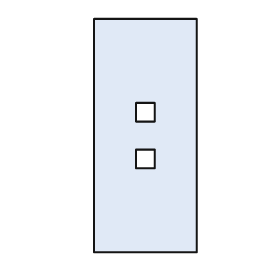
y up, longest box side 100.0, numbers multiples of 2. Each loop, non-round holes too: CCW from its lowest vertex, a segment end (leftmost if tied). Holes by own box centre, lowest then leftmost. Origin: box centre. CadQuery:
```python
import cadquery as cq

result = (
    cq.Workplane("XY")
    .moveTo(-22.0, -50.0)
    .lineTo(22.0, -50.0)
    .lineTo(22.0, 50.0)
    .lineTo(-22.0, 50.0)
    .close()
    .moveTo(-4.0, -14.0)
    .lineTo(4.0, -14.0)
    .lineTo(4.0, -6.0)
    .lineTo(-4.0, -6.0)
    .close()
    .moveTo(-4.0, 6.0)
    .lineTo(4.0, 6.0)
    .lineTo(4.0, 14.0)
    .lineTo(-4.0, 14.0)
    .close()
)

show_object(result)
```